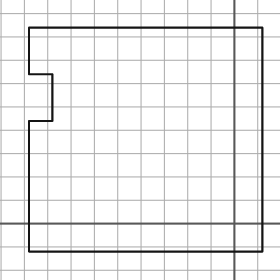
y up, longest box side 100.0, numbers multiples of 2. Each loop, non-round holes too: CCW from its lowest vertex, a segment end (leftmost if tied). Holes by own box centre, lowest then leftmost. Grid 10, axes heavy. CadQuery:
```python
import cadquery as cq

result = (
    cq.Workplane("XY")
    .moveTo(-88.0, -12.0)
    .lineTo(12.0, -12.0)
    .lineTo(12.0, 84.0)
    .lineTo(-88.0, 84.0)
    .lineTo(-88.0, 64.0)
    .lineTo(-78.0, 64.0)
    .lineTo(-78.0, 44.0)
    .lineTo(-88.0, 44.0)
    .close()
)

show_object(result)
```